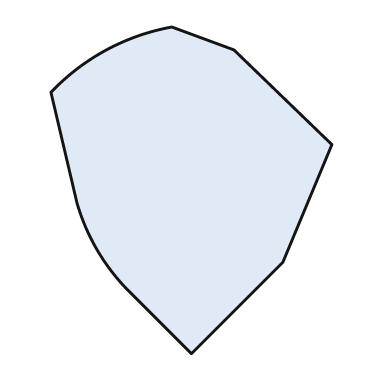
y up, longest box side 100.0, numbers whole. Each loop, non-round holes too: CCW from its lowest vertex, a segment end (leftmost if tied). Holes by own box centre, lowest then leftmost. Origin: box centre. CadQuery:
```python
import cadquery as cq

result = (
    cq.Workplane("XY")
    .moveTo(0.0, -50.0)
    .lineTo(28.0, -22.0)
    .lineTo(43.0, 14.0)
    .lineTo(13.0, 43.0)
    .lineTo(-6.0, 50.0)
    .threePointArc((-26.0, 43.0), (-43.0, 30.0))
    .lineTo(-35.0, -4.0)
    .threePointArc((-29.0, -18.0), (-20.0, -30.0))
    .close()
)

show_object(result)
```